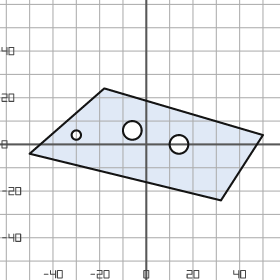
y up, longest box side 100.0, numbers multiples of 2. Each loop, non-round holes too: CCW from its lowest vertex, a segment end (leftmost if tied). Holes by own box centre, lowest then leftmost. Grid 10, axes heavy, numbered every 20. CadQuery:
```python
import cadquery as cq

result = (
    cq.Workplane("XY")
    .moveTo(32.0, -24.0)
    .lineTo(50.0, 4.0)
    .lineTo(-18.0, 24.0)
    .lineTo(-50.0, -4.0)
    .close()
    .moveTo(14.0, 0.0)
    .circle(4.0)
    .moveTo(-30.0, 4.0)
    .circle(2.0)
    .moveTo(-6.0, 6.0)
    .circle(4.0)
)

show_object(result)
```